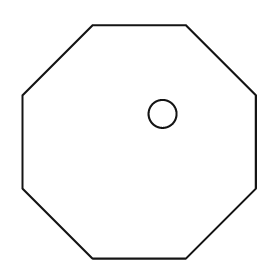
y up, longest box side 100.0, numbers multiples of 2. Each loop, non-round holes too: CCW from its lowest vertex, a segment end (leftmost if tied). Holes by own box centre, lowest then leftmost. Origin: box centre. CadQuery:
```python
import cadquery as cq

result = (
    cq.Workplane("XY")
    .moveTo(-20.0, -50.0)
    .lineTo(20.0, -50.0)
    .lineTo(50.0, -20.0)
    .lineTo(50.0, 20.0)
    .lineTo(20.0, 50.0)
    .lineTo(-20.0, 50.0)
    .lineTo(-50.0, 20.0)
    .lineTo(-50.0, -20.0)
    .close()
    .moveTo(10.0, 12.0)
    .circle(6.0)
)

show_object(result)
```